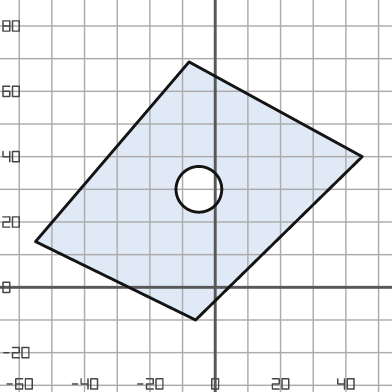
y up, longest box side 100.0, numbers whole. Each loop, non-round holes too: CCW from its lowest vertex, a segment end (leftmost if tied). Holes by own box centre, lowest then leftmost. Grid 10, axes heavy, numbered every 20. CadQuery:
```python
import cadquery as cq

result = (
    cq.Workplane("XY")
    .moveTo(-6.0, -10.0)
    .lineTo(45.0, 40.0)
    .lineTo(-8.0, 69.0)
    .lineTo(-55.0, 14.0)
    .close()
    .moveTo(-5.0, 30.0)
    .circle(7.0)
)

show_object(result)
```